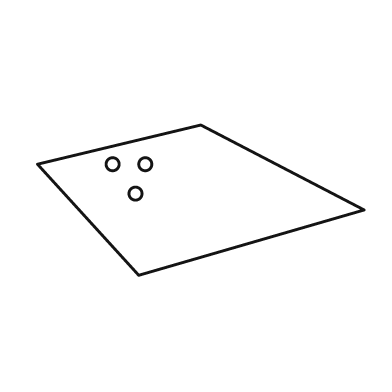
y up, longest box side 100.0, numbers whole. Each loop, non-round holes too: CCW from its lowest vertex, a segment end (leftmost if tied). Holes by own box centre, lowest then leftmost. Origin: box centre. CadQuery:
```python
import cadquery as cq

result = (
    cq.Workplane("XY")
    .moveTo(-19.0, -23.0)
    .lineTo(50.0, -3.0)
    .lineTo(0.0, 23.0)
    .lineTo(-50.0, 11.0)
    .close()
    .moveTo(-20.0, 2.0)
    .circle(2.0)
    .moveTo(-27.0, 11.0)
    .circle(2.0)
    .moveTo(-17.0, 11.0)
    .circle(2.0)
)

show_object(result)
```